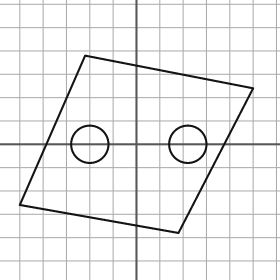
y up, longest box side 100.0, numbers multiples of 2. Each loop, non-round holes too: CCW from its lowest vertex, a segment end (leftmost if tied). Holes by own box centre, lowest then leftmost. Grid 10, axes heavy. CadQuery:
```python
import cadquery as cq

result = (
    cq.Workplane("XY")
    .moveTo(18.0, -38.0)
    .lineTo(50.0, 24.0)
    .lineTo(-22.0, 38.0)
    .lineTo(-50.0, -26.0)
    .close()
    .moveTo(-20.0, 0.0)
    .circle(8.0)
    .moveTo(22.0, 0.0)
    .circle(8.0)
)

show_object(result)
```